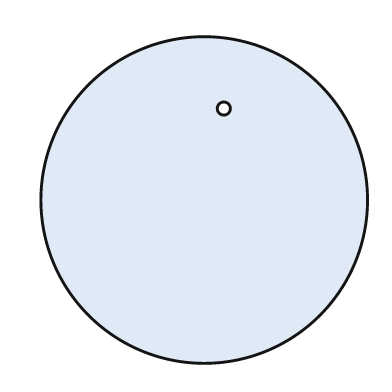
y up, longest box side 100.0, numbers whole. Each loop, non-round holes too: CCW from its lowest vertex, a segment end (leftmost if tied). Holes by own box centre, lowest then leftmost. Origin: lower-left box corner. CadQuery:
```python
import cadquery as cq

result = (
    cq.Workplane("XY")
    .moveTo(50.0, 50.0)
    .circle(50.0)
    .moveTo(56.0, 78.0)
    .circle(2.0)
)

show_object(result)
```